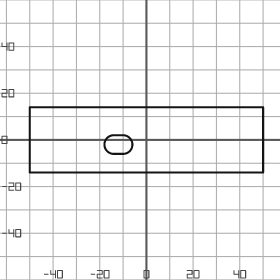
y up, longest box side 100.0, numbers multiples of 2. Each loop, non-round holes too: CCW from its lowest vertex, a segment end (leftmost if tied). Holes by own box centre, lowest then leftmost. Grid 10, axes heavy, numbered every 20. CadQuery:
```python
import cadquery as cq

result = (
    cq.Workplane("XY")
    .moveTo(-50.0, -14.0)
    .lineTo(50.0, -14.0)
    .lineTo(50.0, 14.0)
    .lineTo(-50.0, 14.0)
    .close()
    .moveTo(-14.0, -6.0)
    .lineTo(-10.0, -6.0)
    .threePointArc((-6.0, -2.0), (-10.0, 2.0))
    .lineTo(-14.0, 2.0)
    .threePointArc((-18.0, -2.0), (-14.0, -6.0))
    .close()
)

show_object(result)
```